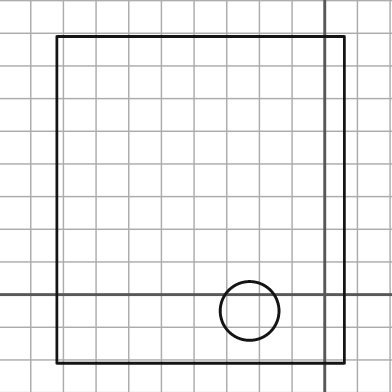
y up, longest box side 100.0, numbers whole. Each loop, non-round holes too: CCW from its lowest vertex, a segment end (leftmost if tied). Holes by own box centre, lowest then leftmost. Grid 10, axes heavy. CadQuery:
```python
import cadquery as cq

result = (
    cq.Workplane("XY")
    .moveTo(-82.0, -21.0)
    .lineTo(6.0, -21.0)
    .lineTo(6.0, 79.0)
    .lineTo(-82.0, 79.0)
    .close()
    .moveTo(-23.0, -5.0)
    .circle(9.0)
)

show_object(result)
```